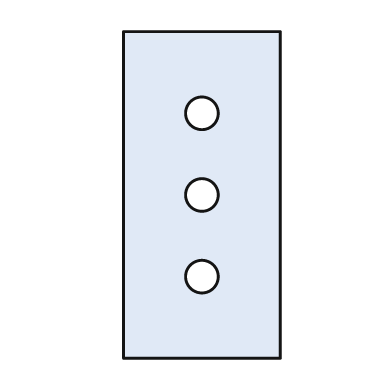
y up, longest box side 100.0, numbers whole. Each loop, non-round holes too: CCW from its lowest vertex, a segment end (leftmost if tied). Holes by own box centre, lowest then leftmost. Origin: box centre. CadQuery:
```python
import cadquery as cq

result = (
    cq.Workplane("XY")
    .moveTo(-24.0, -50.0)
    .lineTo(24.0, -50.0)
    .lineTo(24.0, 50.0)
    .lineTo(-24.0, 50.0)
    .close()
    .moveTo(0.0, -25.0)
    .circle(5.0)
    .moveTo(0.0, 0.0)
    .circle(5.0)
    .moveTo(0.0, 25.0)
    .circle(5.0)
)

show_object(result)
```